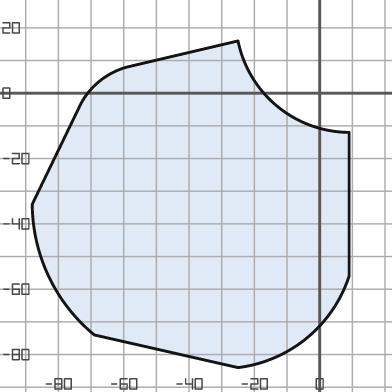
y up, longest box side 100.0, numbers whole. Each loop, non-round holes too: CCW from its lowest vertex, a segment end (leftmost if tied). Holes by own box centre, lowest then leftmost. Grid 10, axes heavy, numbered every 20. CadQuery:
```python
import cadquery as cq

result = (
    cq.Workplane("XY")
    .moveTo(-25.0, -84.0)
    .threePointArc((-4.0, -75.0), (9.0, -56.0))
    .lineTo(9.0, -12.0)
    .threePointArc((-13.0, -4.0), (-25.0, 16.0))
    .lineTo(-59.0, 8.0)
    .threePointArc((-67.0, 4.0), (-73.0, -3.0))
    .lineTo(-88.0, -34.0)
    .threePointArc((-83.0, -56.0), (-69.0, -74.0))
    .close()
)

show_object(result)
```